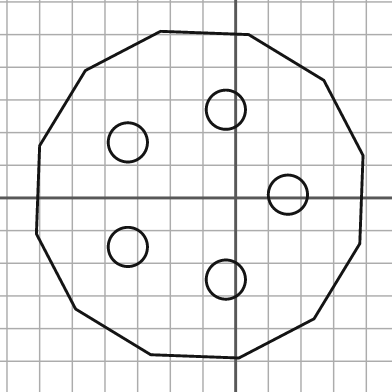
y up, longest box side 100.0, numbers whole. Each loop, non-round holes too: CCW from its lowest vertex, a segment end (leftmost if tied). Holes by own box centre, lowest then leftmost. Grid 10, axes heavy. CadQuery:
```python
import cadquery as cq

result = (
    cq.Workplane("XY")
    .moveTo(1.0, -49.0)
    .lineTo(24.0, -37.0)
    .lineTo(38.0, -14.0)
    .lineTo(39.0, 13.0)
    .lineTo(27.0, 36.0)
    .lineTo(4.0, 50.0)
    .lineTo(-23.0, 51.0)
    .lineTo(-46.0, 39.0)
    .lineTo(-60.0, 16.0)
    .lineTo(-61.0, -11.0)
    .lineTo(-49.0, -34.0)
    .lineTo(-26.0, -48.0)
    .close()
    .moveTo(-3.0, -25.0)
    .circle(6.0)
    .moveTo(-33.0, -15.0)
    .circle(6.0)
    .moveTo(16.0, 1.0)
    .circle(6.0)
    .moveTo(-33.0, 17.0)
    .circle(6.0)
    .moveTo(-3.0, 27.0)
    .circle(6.0)
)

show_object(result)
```